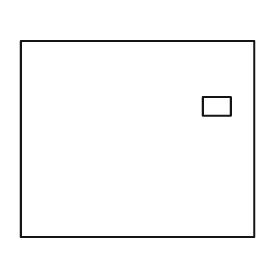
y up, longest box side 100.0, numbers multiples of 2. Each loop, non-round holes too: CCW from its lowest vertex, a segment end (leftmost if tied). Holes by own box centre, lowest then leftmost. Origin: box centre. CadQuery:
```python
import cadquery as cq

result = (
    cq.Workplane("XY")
    .moveTo(-50.0, -42.0)
    .lineTo(50.0, -42.0)
    .lineTo(50.0, 42.0)
    .lineTo(-50.0, 42.0)
    .close()
    .moveTo(28.0, 10.0)
    .lineTo(40.0, 10.0)
    .lineTo(40.0, 18.0)
    .lineTo(28.0, 18.0)
    .close()
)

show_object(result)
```